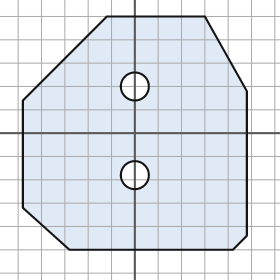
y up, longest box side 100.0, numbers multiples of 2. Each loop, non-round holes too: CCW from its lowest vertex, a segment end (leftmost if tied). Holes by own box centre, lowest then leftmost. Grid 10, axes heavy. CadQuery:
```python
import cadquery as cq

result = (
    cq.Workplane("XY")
    .moveTo(-28.0, -50.0)
    .lineTo(42.0, -50.0)
    .lineTo(48.0, -44.0)
    .lineTo(48.0, 18.0)
    .lineTo(30.0, 50.0)
    .lineTo(-12.0, 50.0)
    .lineTo(-48.0, 14.0)
    .lineTo(-48.0, -32.0)
    .close()
    .moveTo(0.0, -18.0)
    .circle(6.0)
    .moveTo(0.0, 20.0)
    .circle(6.0)
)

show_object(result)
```